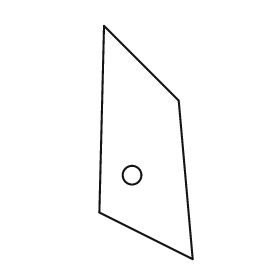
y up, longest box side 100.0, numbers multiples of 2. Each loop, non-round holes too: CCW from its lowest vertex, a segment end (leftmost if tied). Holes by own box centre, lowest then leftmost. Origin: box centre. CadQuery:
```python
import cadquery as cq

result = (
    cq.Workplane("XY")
    .moveTo(20.0, -50.0)
    .lineTo(14.0, 18.0)
    .lineTo(-18.0, 50.0)
    .lineTo(-20.0, -30.0)
    .close()
    .moveTo(-6.0, -14.0)
    .circle(4.0)
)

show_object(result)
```